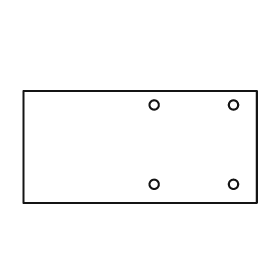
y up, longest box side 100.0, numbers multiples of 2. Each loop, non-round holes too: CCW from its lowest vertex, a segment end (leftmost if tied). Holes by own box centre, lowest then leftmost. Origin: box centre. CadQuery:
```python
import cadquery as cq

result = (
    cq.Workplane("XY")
    .moveTo(-50.0, -24.0)
    .lineTo(50.0, -24.0)
    .lineTo(50.0, 24.0)
    .lineTo(-50.0, 24.0)
    .close()
    .moveTo(6.0, -16.0)
    .circle(2.0)
    .moveTo(40.0, -16.0)
    .circle(2.0)
    .moveTo(6.0, 18.0)
    .circle(2.0)
    .moveTo(40.0, 18.0)
    .circle(2.0)
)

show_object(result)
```